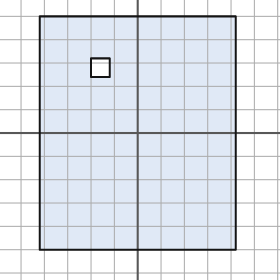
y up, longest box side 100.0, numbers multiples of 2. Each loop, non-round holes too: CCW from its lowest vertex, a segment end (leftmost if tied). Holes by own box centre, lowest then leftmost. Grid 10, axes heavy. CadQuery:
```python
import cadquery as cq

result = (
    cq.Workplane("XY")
    .moveTo(-42.0, -50.0)
    .lineTo(42.0, -50.0)
    .lineTo(42.0, 50.0)
    .lineTo(-42.0, 50.0)
    .close()
    .moveTo(-20.0, 24.0)
    .lineTo(-12.0, 24.0)
    .lineTo(-12.0, 32.0)
    .lineTo(-20.0, 32.0)
    .close()
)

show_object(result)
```